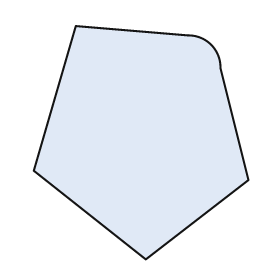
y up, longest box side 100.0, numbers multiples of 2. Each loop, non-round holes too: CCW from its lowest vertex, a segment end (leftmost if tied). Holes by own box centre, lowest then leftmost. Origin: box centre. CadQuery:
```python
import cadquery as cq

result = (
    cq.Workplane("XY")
    .moveTo(2.0, -50.0)
    .lineTo(46.0, -16.0)
    .lineTo(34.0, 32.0)
    .threePointArc((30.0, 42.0), (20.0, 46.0))
    .lineTo(-28.0, 50.0)
    .lineTo(-46.0, -12.0)
    .close()
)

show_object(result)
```